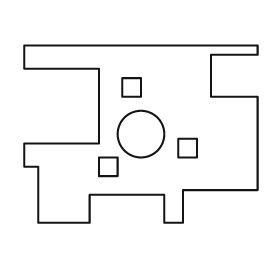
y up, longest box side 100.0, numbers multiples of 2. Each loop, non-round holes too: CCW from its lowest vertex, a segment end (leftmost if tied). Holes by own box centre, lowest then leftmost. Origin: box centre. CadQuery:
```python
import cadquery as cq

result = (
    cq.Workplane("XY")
    .moveTo(-44.0, -38.0)
    .lineTo(-22.0, -38.0)
    .lineTo(-22.0, -26.0)
    .lineTo(10.0, -26.0)
    .lineTo(10.0, -38.0)
    .lineTo(18.0, -38.0)
    .lineTo(18.0, -24.0)
    .lineTo(50.0, -24.0)
    .lineTo(50.0, 16.0)
    .lineTo(30.0, 16.0)
    .lineTo(30.0, 34.0)
    .lineTo(50.0, 34.0)
    .lineTo(50.0, 38.0)
    .lineTo(-50.0, 38.0)
    .lineTo(-50.0, 28.0)
    .lineTo(-18.0, 28.0)
    .lineTo(-18.0, -4.0)
    .lineTo(-50.0, -4.0)
    .lineTo(-50.0, -14.0)
    .lineTo(-44.0, -14.0)
    .close()
    .moveTo(-18.0, -18.0)
    .lineTo(-10.0, -18.0)
    .lineTo(-10.0, -10.0)
    .lineTo(-18.0, -10.0)
    .close()
    .moveTo(16.0, -10.0)
    .lineTo(24.0, -10.0)
    .lineTo(24.0, -2.0)
    .lineTo(16.0, -2.0)
    .close()
    .moveTo(0.0, 0.0)
    .circle(10.0)
    .moveTo(-8.0, 16.0)
    .lineTo(0.0, 16.0)
    .lineTo(0.0, 24.0)
    .lineTo(-8.0, 24.0)
    .close()
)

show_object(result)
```